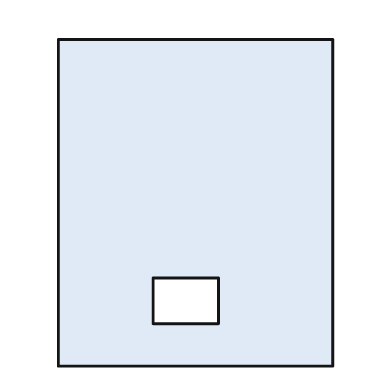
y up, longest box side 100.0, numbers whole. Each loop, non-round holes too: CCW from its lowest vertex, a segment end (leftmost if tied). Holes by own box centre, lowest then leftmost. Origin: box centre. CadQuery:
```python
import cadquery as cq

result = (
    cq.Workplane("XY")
    .moveTo(-42.0, -50.0)
    .lineTo(42.0, -50.0)
    .lineTo(42.0, 50.0)
    .lineTo(-42.0, 50.0)
    .close()
    .moveTo(-13.0, -37.0)
    .lineTo(7.0, -37.0)
    .lineTo(7.0, -23.0)
    .lineTo(-13.0, -23.0)
    .close()
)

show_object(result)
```